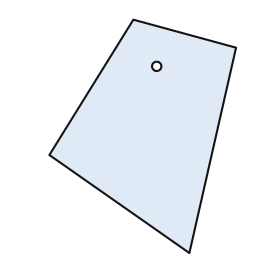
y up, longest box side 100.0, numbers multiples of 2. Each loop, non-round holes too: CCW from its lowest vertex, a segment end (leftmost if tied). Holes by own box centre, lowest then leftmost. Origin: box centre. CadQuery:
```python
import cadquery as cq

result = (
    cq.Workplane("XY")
    .moveTo(20.0, -50.0)
    .lineTo(40.0, 38.0)
    .lineTo(-4.0, 50.0)
    .lineTo(-40.0, -8.0)
    .close()
    .moveTo(6.0, 30.0)
    .circle(2.0)
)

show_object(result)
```